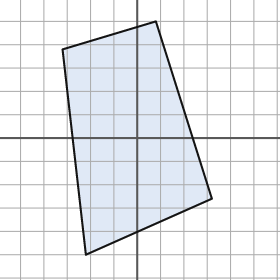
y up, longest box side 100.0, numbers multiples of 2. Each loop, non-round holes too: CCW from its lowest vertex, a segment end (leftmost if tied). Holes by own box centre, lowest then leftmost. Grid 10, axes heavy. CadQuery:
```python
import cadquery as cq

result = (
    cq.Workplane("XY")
    .moveTo(-22.0, -50.0)
    .lineTo(32.0, -26.0)
    .lineTo(8.0, 50.0)
    .lineTo(-32.0, 38.0)
    .close()
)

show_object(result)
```